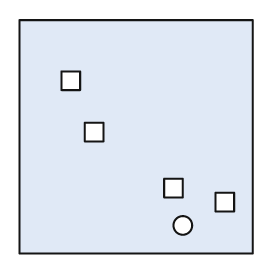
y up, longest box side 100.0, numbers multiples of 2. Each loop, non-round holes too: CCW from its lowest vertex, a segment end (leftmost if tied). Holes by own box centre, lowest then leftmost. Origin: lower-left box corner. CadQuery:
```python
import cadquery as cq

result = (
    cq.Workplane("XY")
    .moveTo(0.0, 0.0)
    .lineTo(100.0, 0.0)
    .lineTo(100.0, 100.0)
    .lineTo(0.0, 100.0)
    .close()
    .moveTo(70.0, 12.0)
    .circle(4.0)
    .moveTo(84.0, 18.0)
    .lineTo(92.0, 18.0)
    .lineTo(92.0, 26.0)
    .lineTo(84.0, 26.0)
    .close()
    .moveTo(62.0, 24.0)
    .lineTo(70.0, 24.0)
    .lineTo(70.0, 32.0)
    .lineTo(62.0, 32.0)
    .close()
    .moveTo(28.0, 48.0)
    .lineTo(36.0, 48.0)
    .lineTo(36.0, 56.0)
    .lineTo(28.0, 56.0)
    .close()
    .moveTo(18.0, 70.0)
    .lineTo(26.0, 70.0)
    .lineTo(26.0, 78.0)
    .lineTo(18.0, 78.0)
    .close()
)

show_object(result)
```